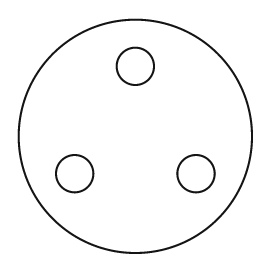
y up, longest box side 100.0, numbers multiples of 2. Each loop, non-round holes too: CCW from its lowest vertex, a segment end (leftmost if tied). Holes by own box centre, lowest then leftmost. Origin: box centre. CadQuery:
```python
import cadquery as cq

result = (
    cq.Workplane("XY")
    .moveTo(0.0, 0.0)
    .circle(50.0)
    .moveTo(-26.0, -16.0)
    .circle(8.0)
    .moveTo(26.0, -16.0)
    .circle(8.0)
    .moveTo(0.0, 30.0)
    .circle(8.0)
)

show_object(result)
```